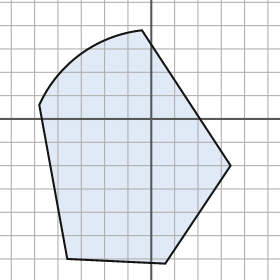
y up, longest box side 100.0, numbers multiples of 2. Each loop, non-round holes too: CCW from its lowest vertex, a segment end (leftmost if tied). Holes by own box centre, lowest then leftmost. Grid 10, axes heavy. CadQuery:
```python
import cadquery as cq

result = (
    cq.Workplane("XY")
    .moveTo(6.0, -62.0)
    .lineTo(34.0, -20.0)
    .lineTo(-4.0, 38.0)
    .threePointArc((-30.0, 28.0), (-48.0, 6.0))
    .lineTo(-36.0, -60.0)
    .close()
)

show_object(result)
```